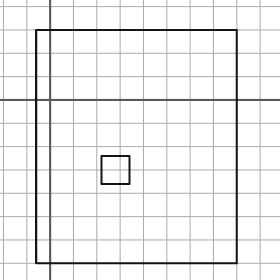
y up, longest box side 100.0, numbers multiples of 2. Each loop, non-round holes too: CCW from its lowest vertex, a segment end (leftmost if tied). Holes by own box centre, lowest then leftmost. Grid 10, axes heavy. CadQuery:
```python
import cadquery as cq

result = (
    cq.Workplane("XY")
    .moveTo(-6.0, -70.0)
    .lineTo(80.0, -70.0)
    .lineTo(80.0, 30.0)
    .lineTo(-6.0, 30.0)
    .close()
    .moveTo(22.0, -36.0)
    .lineTo(34.0, -36.0)
    .lineTo(34.0, -24.0)
    .lineTo(22.0, -24.0)
    .close()
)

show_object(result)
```